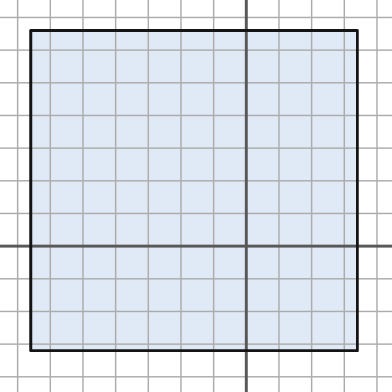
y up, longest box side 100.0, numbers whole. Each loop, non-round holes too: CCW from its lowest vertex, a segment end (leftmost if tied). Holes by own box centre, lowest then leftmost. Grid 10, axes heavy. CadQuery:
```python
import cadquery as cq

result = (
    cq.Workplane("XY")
    .moveTo(-66.0, -32.0)
    .lineTo(34.0, -32.0)
    .lineTo(34.0, 66.0)
    .lineTo(-66.0, 66.0)
    .close()
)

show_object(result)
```